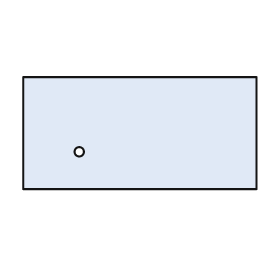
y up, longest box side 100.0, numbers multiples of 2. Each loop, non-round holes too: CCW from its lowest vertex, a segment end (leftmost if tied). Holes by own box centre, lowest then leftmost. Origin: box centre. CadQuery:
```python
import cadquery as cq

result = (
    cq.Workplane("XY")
    .moveTo(-50.0, -24.0)
    .lineTo(50.0, -24.0)
    .lineTo(50.0, 24.0)
    .lineTo(-50.0, 24.0)
    .close()
    .moveTo(-26.0, -8.0)
    .circle(2.0)
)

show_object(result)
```